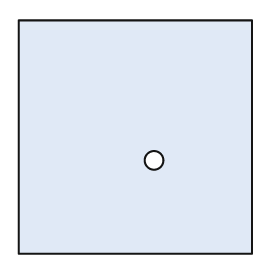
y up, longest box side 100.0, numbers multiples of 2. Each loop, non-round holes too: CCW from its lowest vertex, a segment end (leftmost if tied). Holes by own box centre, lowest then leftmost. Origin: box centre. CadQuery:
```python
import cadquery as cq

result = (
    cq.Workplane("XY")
    .moveTo(-50.0, -50.0)
    .lineTo(50.0, -50.0)
    .lineTo(50.0, 50.0)
    .lineTo(-50.0, 50.0)
    .close()
    .moveTo(8.0, -10.0)
    .circle(4.0)
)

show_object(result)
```